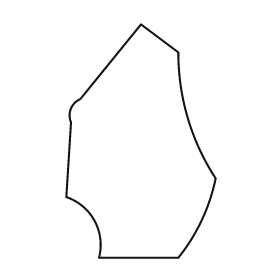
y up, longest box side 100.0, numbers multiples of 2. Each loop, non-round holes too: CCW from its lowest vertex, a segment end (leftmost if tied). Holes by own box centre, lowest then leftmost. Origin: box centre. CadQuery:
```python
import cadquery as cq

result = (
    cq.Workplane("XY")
    .moveTo(-18.0, -50.0)
    .lineTo(16.0, -50.0)
    .threePointArc((26.0, -34.0), (32.0, -16.0))
    .threePointArc((20.0, 10.0), (16.0, 38.0))
    .lineTo(0.0, 50.0)
    .lineTo(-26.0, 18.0)
    .threePointArc((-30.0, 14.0), (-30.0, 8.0))
    .lineTo(-32.0, -24.0)
    .threePointArc((-20.0, -34.0), (-18.0, -50.0))
    .close()
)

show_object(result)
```